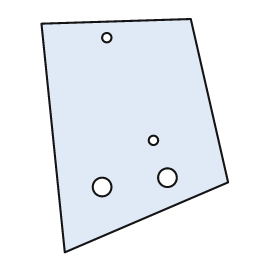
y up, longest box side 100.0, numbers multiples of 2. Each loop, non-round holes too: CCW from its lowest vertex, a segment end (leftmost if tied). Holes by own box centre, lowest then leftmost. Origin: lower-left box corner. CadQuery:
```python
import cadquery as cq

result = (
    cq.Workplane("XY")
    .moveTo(10.0, 0.0)
    .lineTo(80.0, 30.0)
    .lineTo(64.0, 100.0)
    .lineTo(0.0, 98.0)
    .close()
    .moveTo(26.0, 28.0)
    .circle(4.0)
    .moveTo(54.0, 32.0)
    .circle(4.0)
    .moveTo(48.0, 48.0)
    .circle(2.0)
    .moveTo(28.0, 92.0)
    .circle(2.0)
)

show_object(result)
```